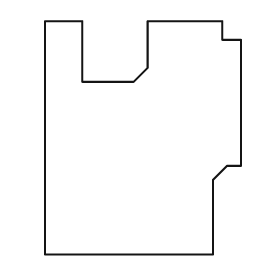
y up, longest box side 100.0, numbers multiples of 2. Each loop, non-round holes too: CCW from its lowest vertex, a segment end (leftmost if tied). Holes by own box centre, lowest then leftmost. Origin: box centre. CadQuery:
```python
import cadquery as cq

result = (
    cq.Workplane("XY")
    .moveTo(-42.0, -50.0)
    .lineTo(30.0, -50.0)
    .lineTo(30.0, -18.0)
    .lineTo(36.0, -12.0)
    .lineTo(42.0, -12.0)
    .lineTo(42.0, 42.0)
    .lineTo(34.0, 42.0)
    .lineTo(34.0, 50.0)
    .lineTo(2.0, 50.0)
    .lineTo(2.0, 30.0)
    .lineTo(-4.0, 24.0)
    .lineTo(-26.0, 24.0)
    .lineTo(-26.0, 50.0)
    .lineTo(-42.0, 50.0)
    .close()
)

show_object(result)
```